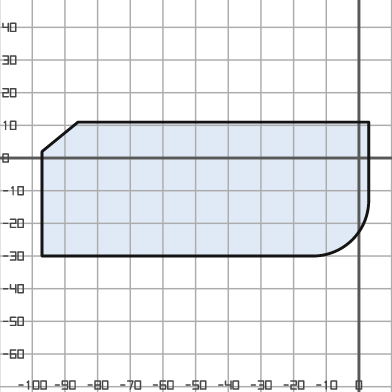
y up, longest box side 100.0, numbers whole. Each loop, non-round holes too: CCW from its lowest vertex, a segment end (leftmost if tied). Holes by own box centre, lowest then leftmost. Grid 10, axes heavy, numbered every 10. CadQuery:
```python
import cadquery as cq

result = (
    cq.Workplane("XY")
    .moveTo(-97.0, -30.0)
    .lineTo(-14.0, -30.0)
    .threePointArc((-2.0, -25.0), (3.0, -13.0))
    .lineTo(3.0, 11.0)
    .lineTo(-86.0, 11.0)
    .lineTo(-97.0, 2.0)
    .close()
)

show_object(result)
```